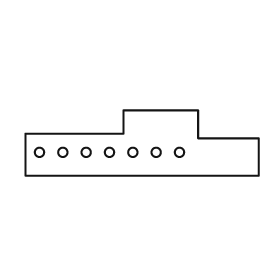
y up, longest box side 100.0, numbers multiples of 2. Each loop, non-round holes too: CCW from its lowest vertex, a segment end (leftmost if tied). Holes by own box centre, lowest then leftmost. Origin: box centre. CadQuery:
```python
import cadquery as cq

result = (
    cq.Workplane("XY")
    .moveTo(-50.0, -14.0)
    .lineTo(50.0, -14.0)
    .lineTo(50.0, 2.0)
    .lineTo(24.0, 2.0)
    .lineTo(24.0, 14.0)
    .lineTo(-8.0, 14.0)
    .lineTo(-8.0, 4.0)
    .lineTo(-50.0, 4.0)
    .close()
    .moveTo(-44.0, -4.0)
    .circle(2.0)
    .moveTo(-34.0, -4.0)
    .circle(2.0)
    .moveTo(-24.0, -4.0)
    .circle(2.0)
    .moveTo(-14.0, -4.0)
    .circle(2.0)
    .moveTo(-4.0, -4.0)
    .circle(2.0)
    .moveTo(6.0, -4.0)
    .circle(2.0)
    .moveTo(16.0, -4.0)
    .circle(2.0)
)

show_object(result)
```